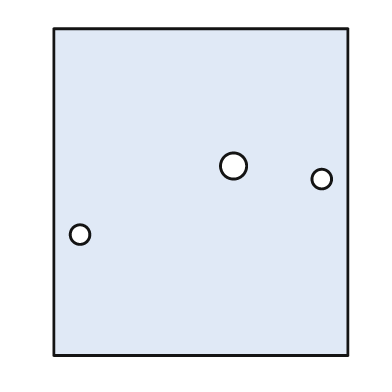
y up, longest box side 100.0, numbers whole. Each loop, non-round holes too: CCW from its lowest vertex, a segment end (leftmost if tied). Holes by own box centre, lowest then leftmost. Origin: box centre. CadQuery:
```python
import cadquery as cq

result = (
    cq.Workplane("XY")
    .moveTo(-45.0, -50.0)
    .lineTo(45.0, -50.0)
    .lineTo(45.0, 50.0)
    .lineTo(-45.0, 50.0)
    .close()
    .moveTo(-37.0, -13.0)
    .circle(3.0)
    .moveTo(37.0, 4.0)
    .circle(3.0)
    .moveTo(10.0, 8.0)
    .circle(4.0)
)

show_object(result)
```